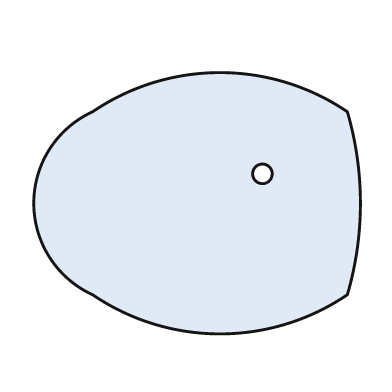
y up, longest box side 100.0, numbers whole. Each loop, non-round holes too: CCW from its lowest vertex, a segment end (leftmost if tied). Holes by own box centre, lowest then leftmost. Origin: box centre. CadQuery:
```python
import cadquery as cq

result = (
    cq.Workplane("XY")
    .moveTo(-32.0, -28.0)
    .threePointArc((7.0, -40.0), (46.0, -28.0))
    .threePointArc((50.0, 0.0), (46.0, 28.0))
    .threePointArc((7.0, 40.0), (-32.0, 28.0))
    .threePointArc((-50.0, 0.0), (-32.0, -28.0))
    .close()
    .moveTo(20.0, 9.0)
    .circle(3.0)
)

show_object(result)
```